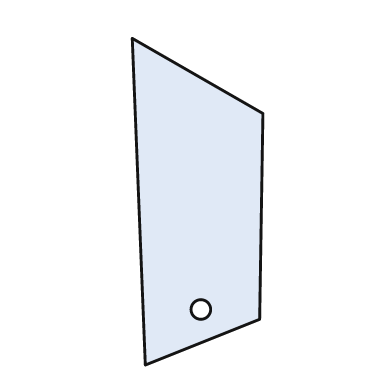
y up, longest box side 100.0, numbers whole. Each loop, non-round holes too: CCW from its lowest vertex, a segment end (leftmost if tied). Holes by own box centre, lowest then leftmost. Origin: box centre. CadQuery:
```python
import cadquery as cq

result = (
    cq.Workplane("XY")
    .moveTo(-16.0, -50.0)
    .lineTo(19.0, -36.0)
    .lineTo(20.0, 27.0)
    .lineTo(-20.0, 50.0)
    .close()
    .moveTo(1.0, -33.0)
    .circle(3.0)
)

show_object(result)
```